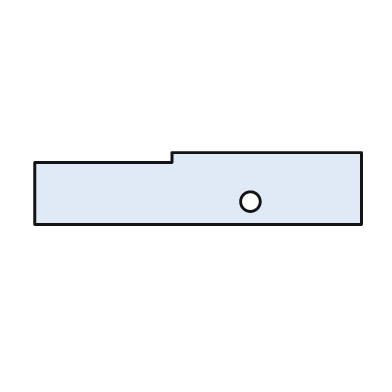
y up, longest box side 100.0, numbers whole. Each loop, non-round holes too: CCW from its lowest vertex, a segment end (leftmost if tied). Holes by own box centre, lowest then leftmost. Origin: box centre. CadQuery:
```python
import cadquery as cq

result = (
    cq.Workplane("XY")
    .moveTo(-50.0, -11.0)
    .lineTo(50.0, -11.0)
    .lineTo(50.0, 11.0)
    .lineTo(-8.0, 11.0)
    .lineTo(-8.0, 8.0)
    .lineTo(-50.0, 8.0)
    .close()
    .moveTo(16.0, -4.0)
    .circle(3.0)
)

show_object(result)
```